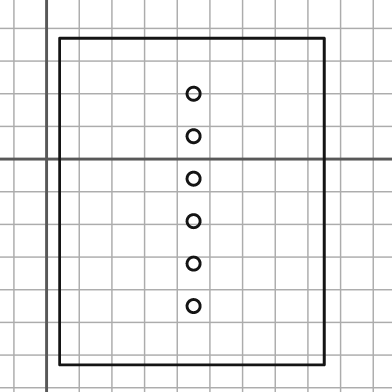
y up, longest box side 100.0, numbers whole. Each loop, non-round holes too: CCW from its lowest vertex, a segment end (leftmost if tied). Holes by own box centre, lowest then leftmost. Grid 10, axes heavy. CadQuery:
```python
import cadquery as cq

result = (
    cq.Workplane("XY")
    .moveTo(4.0, -63.0)
    .lineTo(85.0, -63.0)
    .lineTo(85.0, 37.0)
    .lineTo(4.0, 37.0)
    .close()
    .moveTo(45.0, -45.0)
    .circle(2.0)
    .moveTo(45.0, -32.0)
    .circle(2.0)
    .moveTo(45.0, -19.0)
    .circle(2.0)
    .moveTo(45.0, -6.0)
    .circle(2.0)
    .moveTo(45.0, 7.0)
    .circle(2.0)
    .moveTo(45.0, 20.0)
    .circle(2.0)
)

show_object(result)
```